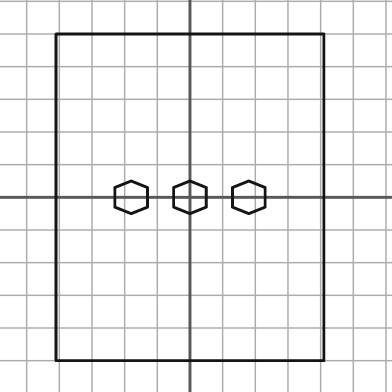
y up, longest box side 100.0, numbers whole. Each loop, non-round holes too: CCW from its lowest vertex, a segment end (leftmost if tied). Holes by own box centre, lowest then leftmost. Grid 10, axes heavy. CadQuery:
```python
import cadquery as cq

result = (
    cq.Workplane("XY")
    .moveTo(-41.0, -50.0)
    .lineTo(41.0, -50.0)
    .lineTo(41.0, 50.0)
    .lineTo(-41.0, 50.0)
    .close()
    .moveTo(-18.0, -5.0)
    .lineTo(-13.0, -3.0)
    .lineTo(-13.0, 3.0)
    .lineTo(-18.0, 5.0)
    .lineTo(-23.0, 3.0)
    .lineTo(-23.0, -3.0)
    .close()
    .moveTo(0.0, -5.0)
    .lineTo(5.0, -3.0)
    .lineTo(5.0, 3.0)
    .lineTo(0.0, 5.0)
    .lineTo(-5.0, 3.0)
    .lineTo(-5.0, -3.0)
    .close()
    .moveTo(18.0, -5.0)
    .lineTo(23.0, -3.0)
    .lineTo(23.0, 3.0)
    .lineTo(18.0, 5.0)
    .lineTo(13.0, 3.0)
    .lineTo(13.0, -3.0)
    .close()
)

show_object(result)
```